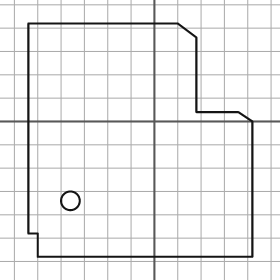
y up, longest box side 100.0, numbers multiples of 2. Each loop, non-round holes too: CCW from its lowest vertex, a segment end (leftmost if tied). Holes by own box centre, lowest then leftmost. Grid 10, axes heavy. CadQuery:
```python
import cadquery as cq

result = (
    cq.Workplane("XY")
    .moveTo(-50.0, -58.0)
    .lineTo(42.0, -58.0)
    .lineTo(42.0, 0.0)
    .lineTo(36.0, 4.0)
    .lineTo(18.0, 4.0)
    .lineTo(18.0, 36.0)
    .lineTo(10.0, 42.0)
    .lineTo(-54.0, 42.0)
    .lineTo(-54.0, -48.0)
    .lineTo(-50.0, -48.0)
    .close()
    .moveTo(-36.0, -34.0)
    .circle(4.0)
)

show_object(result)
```